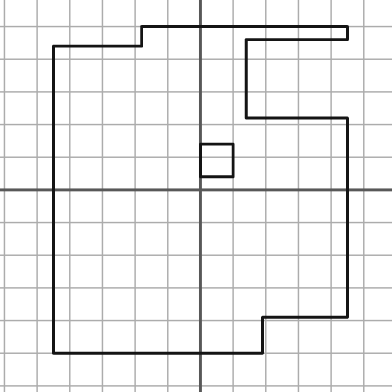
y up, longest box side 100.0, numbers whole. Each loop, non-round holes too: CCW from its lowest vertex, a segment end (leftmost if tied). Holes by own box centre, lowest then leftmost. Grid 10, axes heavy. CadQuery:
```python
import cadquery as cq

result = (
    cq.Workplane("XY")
    .moveTo(-45.0, -50.0)
    .lineTo(19.0, -50.0)
    .lineTo(19.0, -39.0)
    .lineTo(45.0, -39.0)
    .lineTo(45.0, 22.0)
    .lineTo(14.0, 22.0)
    .lineTo(14.0, 46.0)
    .lineTo(45.0, 46.0)
    .lineTo(45.0, 50.0)
    .lineTo(-18.0, 50.0)
    .lineTo(-18.0, 44.0)
    .lineTo(-45.0, 44.0)
    .close()
    .moveTo(0.0, 4.0)
    .lineTo(10.0, 4.0)
    .lineTo(10.0, 14.0)
    .lineTo(0.0, 14.0)
    .close()
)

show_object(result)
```